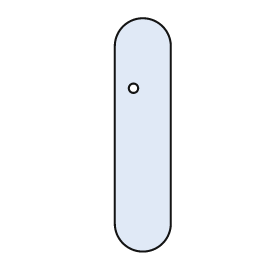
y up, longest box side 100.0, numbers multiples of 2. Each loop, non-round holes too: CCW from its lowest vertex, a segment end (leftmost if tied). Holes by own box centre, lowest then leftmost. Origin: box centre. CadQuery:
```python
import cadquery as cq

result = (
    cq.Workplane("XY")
    .moveTo(-12.0, -38.0)
    .threePointArc((0.0, -50.0), (12.0, -38.0))
    .lineTo(12.0, 38.0)
    .threePointArc((0.0, 50.0), (-12.0, 38.0))
    .close()
    .moveTo(-4.0, 20.0)
    .circle(2.0)
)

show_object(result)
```